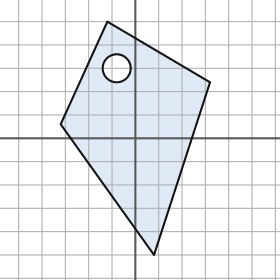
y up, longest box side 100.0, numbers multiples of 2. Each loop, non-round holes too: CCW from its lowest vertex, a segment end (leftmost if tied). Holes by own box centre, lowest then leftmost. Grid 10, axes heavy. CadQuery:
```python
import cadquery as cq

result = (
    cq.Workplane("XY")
    .moveTo(8.0, -50.0)
    .lineTo(32.0, 24.0)
    .lineTo(-12.0, 50.0)
    .lineTo(-32.0, 6.0)
    .close()
    .moveTo(-8.0, 30.0)
    .circle(6.0)
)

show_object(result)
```